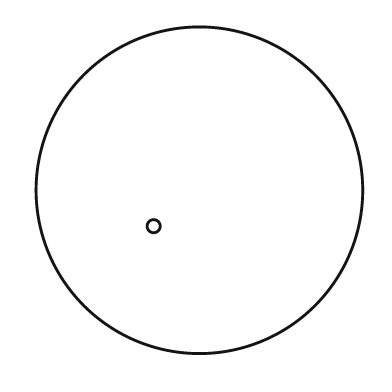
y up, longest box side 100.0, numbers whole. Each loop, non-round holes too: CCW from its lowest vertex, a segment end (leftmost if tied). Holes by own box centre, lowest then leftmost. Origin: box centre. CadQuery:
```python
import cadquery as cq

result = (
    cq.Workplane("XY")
    .moveTo(0.0, 0.0)
    .circle(50.0)
    .moveTo(-14.0, -11.0)
    .circle(2.0)
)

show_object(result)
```